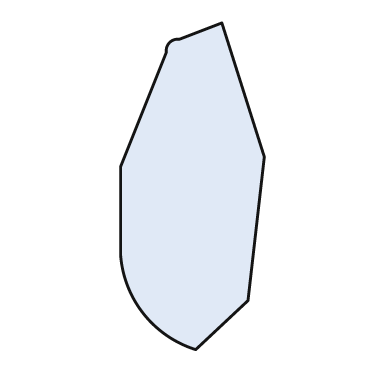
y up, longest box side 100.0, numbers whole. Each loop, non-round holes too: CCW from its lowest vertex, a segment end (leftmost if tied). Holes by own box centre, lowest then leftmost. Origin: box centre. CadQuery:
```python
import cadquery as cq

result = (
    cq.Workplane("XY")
    .moveTo(1.0, -50.0)
    .lineTo(17.0, -35.0)
    .lineTo(22.0, 9.0)
    .lineTo(9.0, 50.0)
    .lineTo(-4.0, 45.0)
    .threePointArc((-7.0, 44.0), (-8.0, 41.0))
    .lineTo(-22.0, 6.0)
    .lineTo(-22.0, -21.0)
    .threePointArc((-15.0, -39.0), (1.0, -50.0))
    .close()
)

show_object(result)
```